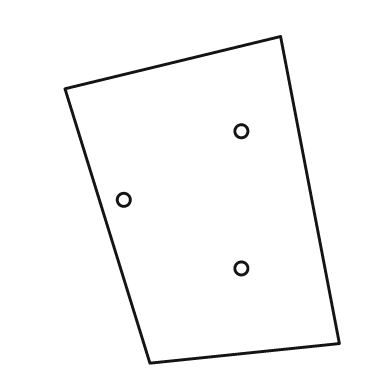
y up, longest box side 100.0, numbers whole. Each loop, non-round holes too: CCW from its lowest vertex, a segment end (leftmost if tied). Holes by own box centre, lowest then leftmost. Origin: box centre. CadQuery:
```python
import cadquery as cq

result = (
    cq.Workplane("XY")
    .moveTo(-16.0, -50.0)
    .lineTo(42.0, -44.0)
    .lineTo(24.0, 50.0)
    .lineTo(-42.0, 34.0)
    .close()
    .moveTo(12.0, -21.0)
    .circle(2.0)
    .moveTo(-24.0, 0.0)
    .circle(2.0)
    .moveTo(12.0, 21.0)
    .circle(2.0)
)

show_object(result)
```